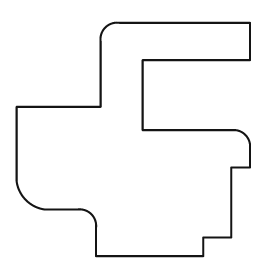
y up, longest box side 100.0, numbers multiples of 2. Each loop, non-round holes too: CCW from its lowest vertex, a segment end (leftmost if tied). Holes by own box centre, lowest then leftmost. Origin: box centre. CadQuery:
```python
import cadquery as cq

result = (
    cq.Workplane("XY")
    .moveTo(-16.0, -50.0)
    .lineTo(30.0, -50.0)
    .lineTo(30.0, -42.0)
    .lineTo(42.0, -42.0)
    .lineTo(42.0, -12.0)
    .lineTo(50.0, -12.0)
    .lineTo(50.0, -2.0)
    .threePointArc((48.0, 2.0), (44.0, 4.0))
    .lineTo(4.0, 4.0)
    .lineTo(4.0, 34.0)
    .lineTo(50.0, 34.0)
    .lineTo(50.0, 50.0)
    .lineTo(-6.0, 50.0)
    .threePointArc((-12.0, 48.0), (-14.0, 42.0))
    .lineTo(-14.0, 14.0)
    .lineTo(-50.0, 14.0)
    .lineTo(-50.0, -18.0)
    .threePointArc((-46.0, -26.0), (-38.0, -30.0))
    .lineTo(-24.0, -30.0)
    .threePointArc((-18.0, -32.0), (-16.0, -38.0))
    .close()
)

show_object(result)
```